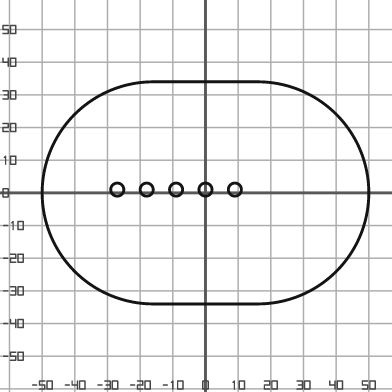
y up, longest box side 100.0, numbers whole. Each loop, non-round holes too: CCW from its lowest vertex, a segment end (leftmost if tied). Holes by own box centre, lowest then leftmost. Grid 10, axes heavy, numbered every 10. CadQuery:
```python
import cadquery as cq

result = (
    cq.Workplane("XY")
    .moveTo(-16.0, -34.0)
    .lineTo(16.0, -34.0)
    .threePointArc((50.0, 0.0), (16.0, 34.0))
    .lineTo(-16.0, 34.0)
    .threePointArc((-50.0, 0.0), (-16.0, -34.0))
    .close()
    .moveTo(-27.0, 1.0)
    .circle(2.0)
    .moveTo(-18.0, 1.0)
    .circle(2.0)
    .moveTo(-9.0, 1.0)
    .circle(2.0)
    .moveTo(0.0, 1.0)
    .circle(2.0)
    .moveTo(9.0, 1.0)
    .circle(2.0)
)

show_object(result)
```